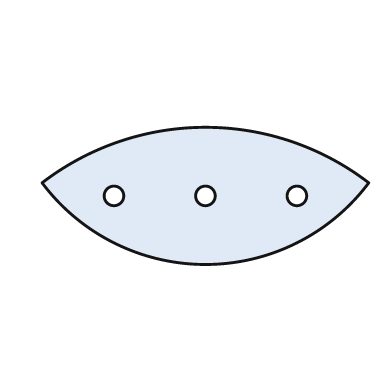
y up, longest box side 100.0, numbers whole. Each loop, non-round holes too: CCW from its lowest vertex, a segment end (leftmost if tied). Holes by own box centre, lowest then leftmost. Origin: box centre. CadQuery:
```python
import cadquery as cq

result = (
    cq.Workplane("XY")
    .moveTo(-50.0, 4.0)
    .threePointArc((0.0, -21.0), (50.0, 4.0))
    .threePointArc((0.0, 21.0), (-50.0, 4.0))
    .close()
    .moveTo(-28.0, 0.0)
    .circle(3.0)
    .moveTo(0.0, 0.0)
    .circle(3.0)
    .moveTo(28.0, 0.0)
    .circle(3.0)
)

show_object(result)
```